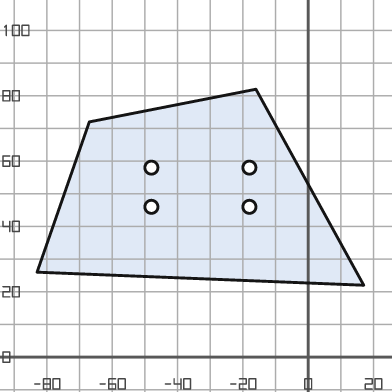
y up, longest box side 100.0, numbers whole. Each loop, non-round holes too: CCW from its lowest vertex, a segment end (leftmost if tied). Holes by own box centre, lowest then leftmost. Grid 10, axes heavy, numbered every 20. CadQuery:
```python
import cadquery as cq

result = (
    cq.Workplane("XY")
    .moveTo(17.0, 22.0)
    .lineTo(-16.0, 82.0)
    .lineTo(-67.0, 72.0)
    .lineTo(-83.0, 26.0)
    .close()
    .moveTo(-48.0, 46.0)
    .circle(2.0)
    .moveTo(-18.0, 46.0)
    .circle(2.0)
    .moveTo(-48.0, 58.0)
    .circle(2.0)
    .moveTo(-18.0, 58.0)
    .circle(2.0)
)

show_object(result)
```